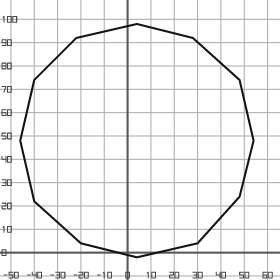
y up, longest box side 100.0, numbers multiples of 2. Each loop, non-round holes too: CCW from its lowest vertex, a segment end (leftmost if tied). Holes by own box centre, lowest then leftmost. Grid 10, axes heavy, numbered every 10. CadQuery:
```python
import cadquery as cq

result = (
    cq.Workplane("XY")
    .moveTo(4.0, -2.0)
    .lineTo(30.0, 4.0)
    .lineTo(48.0, 24.0)
    .lineTo(54.0, 48.0)
    .lineTo(48.0, 74.0)
    .lineTo(28.0, 92.0)
    .lineTo(4.0, 98.0)
    .lineTo(-22.0, 92.0)
    .lineTo(-40.0, 74.0)
    .lineTo(-46.0, 48.0)
    .lineTo(-40.0, 22.0)
    .lineTo(-20.0, 4.0)
    .close()
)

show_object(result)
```